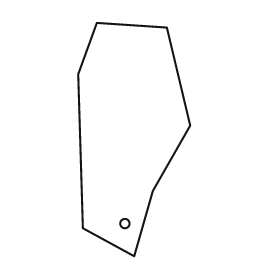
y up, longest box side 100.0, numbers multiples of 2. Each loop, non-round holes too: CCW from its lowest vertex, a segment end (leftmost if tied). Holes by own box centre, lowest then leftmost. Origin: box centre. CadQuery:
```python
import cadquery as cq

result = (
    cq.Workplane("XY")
    .moveTo(0.0, -50.0)
    .lineTo(8.0, -22.0)
    .lineTo(24.0, 6.0)
    .lineTo(14.0, 48.0)
    .lineTo(-16.0, 50.0)
    .lineTo(-24.0, 28.0)
    .lineTo(-22.0, -38.0)
    .close()
    .moveTo(-4.0, -36.0)
    .circle(2.0)
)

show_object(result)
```